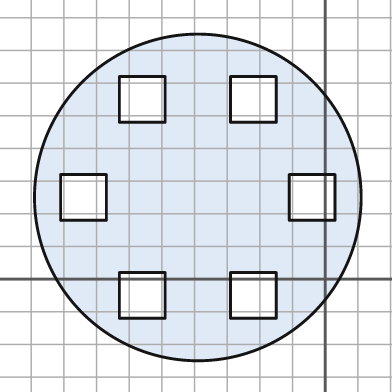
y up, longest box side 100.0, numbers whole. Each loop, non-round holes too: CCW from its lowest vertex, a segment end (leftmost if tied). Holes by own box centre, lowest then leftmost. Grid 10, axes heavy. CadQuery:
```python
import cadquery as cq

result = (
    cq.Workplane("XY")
    .moveTo(-39.0, 25.0)
    .circle(50.0)
    .moveTo(-63.0, -12.0)
    .lineTo(-49.0, -12.0)
    .lineTo(-49.0, 2.0)
    .lineTo(-63.0, 2.0)
    .close()
    .moveTo(-29.0, -12.0)
    .lineTo(-15.0, -12.0)
    .lineTo(-15.0, 2.0)
    .lineTo(-29.0, 2.0)
    .close()
    .moveTo(-81.0, 18.0)
    .lineTo(-67.0, 18.0)
    .lineTo(-67.0, 32.0)
    .lineTo(-81.0, 32.0)
    .close()
    .moveTo(-11.0, 18.0)
    .lineTo(3.0, 18.0)
    .lineTo(3.0, 32.0)
    .lineTo(-11.0, 32.0)
    .close()
    .moveTo(-63.0, 48.0)
    .lineTo(-49.0, 48.0)
    .lineTo(-49.0, 62.0)
    .lineTo(-63.0, 62.0)
    .close()
    .moveTo(-29.0, 48.0)
    .lineTo(-15.0, 48.0)
    .lineTo(-15.0, 62.0)
    .lineTo(-29.0, 62.0)
    .close()
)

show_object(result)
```